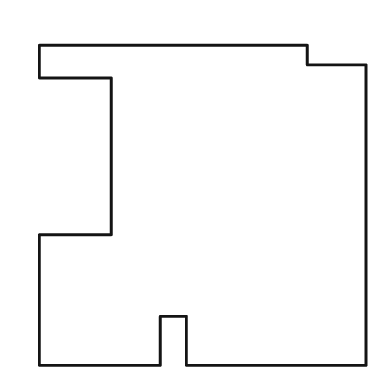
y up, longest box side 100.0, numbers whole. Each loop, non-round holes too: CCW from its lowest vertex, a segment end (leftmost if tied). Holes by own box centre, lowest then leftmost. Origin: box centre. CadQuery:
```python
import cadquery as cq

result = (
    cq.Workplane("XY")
    .moveTo(-50.0, -49.0)
    .lineTo(-13.0, -49.0)
    .lineTo(-13.0, -34.0)
    .lineTo(-5.0, -34.0)
    .lineTo(-5.0, -49.0)
    .lineTo(50.0, -49.0)
    .lineTo(50.0, 43.0)
    .lineTo(32.0, 43.0)
    .lineTo(32.0, 49.0)
    .lineTo(-50.0, 49.0)
    .lineTo(-50.0, 39.0)
    .lineTo(-28.0, 39.0)
    .lineTo(-28.0, -9.0)
    .lineTo(-50.0, -9.0)
    .close()
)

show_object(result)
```